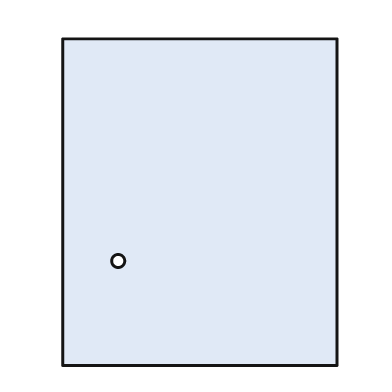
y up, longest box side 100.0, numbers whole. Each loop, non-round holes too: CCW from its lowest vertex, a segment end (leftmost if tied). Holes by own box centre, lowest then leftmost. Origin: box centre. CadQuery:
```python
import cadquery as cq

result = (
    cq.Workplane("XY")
    .moveTo(-42.0, -50.0)
    .lineTo(42.0, -50.0)
    .lineTo(42.0, 50.0)
    .lineTo(-42.0, 50.0)
    .close()
    .moveTo(-25.0, -18.0)
    .circle(2.0)
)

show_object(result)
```